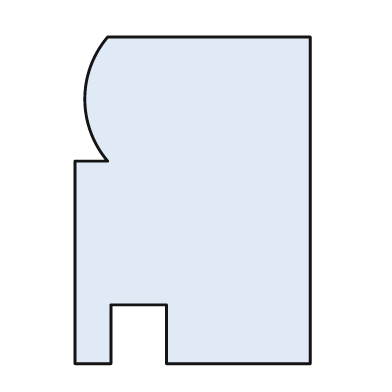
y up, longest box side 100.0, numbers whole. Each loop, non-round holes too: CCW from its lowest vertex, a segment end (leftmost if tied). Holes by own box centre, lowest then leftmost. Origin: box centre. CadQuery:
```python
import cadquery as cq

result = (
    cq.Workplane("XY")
    .moveTo(-36.0, -50.0)
    .lineTo(-25.0, -50.0)
    .lineTo(-25.0, -32.0)
    .lineTo(-8.0, -32.0)
    .lineTo(-8.0, -50.0)
    .lineTo(36.0, -50.0)
    .lineTo(36.0, 50.0)
    .lineTo(-26.0, 50.0)
    .threePointArc((-33.0, 31.0), (-26.0, 12.0))
    .lineTo(-36.0, 12.0)
    .close()
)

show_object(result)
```